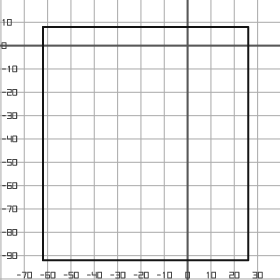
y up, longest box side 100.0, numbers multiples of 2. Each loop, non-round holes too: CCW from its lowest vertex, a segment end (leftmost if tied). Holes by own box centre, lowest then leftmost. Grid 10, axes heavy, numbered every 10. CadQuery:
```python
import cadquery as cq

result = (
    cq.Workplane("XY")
    .moveTo(-62.0, -92.0)
    .lineTo(26.0, -92.0)
    .lineTo(26.0, 8.0)
    .lineTo(-62.0, 8.0)
    .close()
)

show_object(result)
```